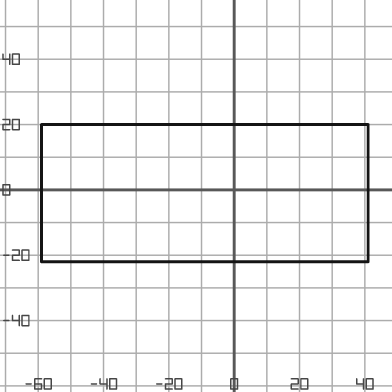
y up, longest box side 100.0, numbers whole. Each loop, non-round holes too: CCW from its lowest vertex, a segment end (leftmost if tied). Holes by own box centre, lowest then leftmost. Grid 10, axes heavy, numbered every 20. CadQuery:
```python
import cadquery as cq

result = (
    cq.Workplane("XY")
    .moveTo(-59.0, -22.0)
    .lineTo(41.0, -22.0)
    .lineTo(41.0, 20.0)
    .lineTo(-59.0, 20.0)
    .close()
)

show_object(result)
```